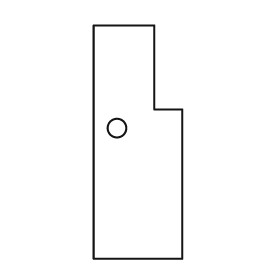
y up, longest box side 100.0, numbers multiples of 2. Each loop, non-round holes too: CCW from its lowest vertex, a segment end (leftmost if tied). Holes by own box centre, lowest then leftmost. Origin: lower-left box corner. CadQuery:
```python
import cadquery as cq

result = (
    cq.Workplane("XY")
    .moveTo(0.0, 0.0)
    .lineTo(38.0, 0.0)
    .lineTo(38.0, 64.0)
    .lineTo(26.0, 64.0)
    .lineTo(26.0, 100.0)
    .lineTo(0.0, 100.0)
    .close()
    .moveTo(10.0, 56.0)
    .circle(4.0)
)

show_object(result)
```